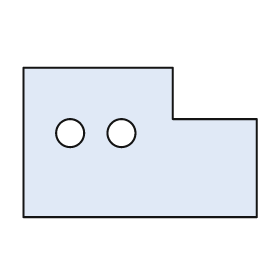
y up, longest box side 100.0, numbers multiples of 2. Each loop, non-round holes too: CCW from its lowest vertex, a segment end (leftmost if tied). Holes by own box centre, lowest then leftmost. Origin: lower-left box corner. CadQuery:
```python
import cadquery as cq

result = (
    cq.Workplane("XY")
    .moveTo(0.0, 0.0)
    .lineTo(100.0, 0.0)
    .lineTo(100.0, 42.0)
    .lineTo(64.0, 42.0)
    .lineTo(64.0, 64.0)
    .lineTo(0.0, 64.0)
    .close()
    .moveTo(20.0, 36.0)
    .circle(6.0)
    .moveTo(42.0, 36.0)
    .circle(6.0)
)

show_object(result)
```